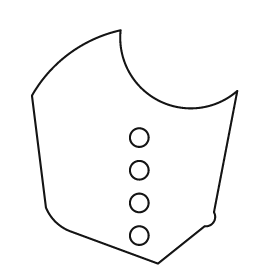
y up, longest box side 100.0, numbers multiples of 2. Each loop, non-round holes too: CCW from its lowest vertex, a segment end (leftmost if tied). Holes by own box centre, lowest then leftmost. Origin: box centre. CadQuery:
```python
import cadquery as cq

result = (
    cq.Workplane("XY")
    .moveTo(10.0, -50.0)
    .lineTo(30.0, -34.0)
    .threePointArc((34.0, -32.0), (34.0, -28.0))
    .lineTo(44.0, 24.0)
    .threePointArc((10.0, 20.0), (-6.0, 50.0))
    .threePointArc((-28.0, 40.0), (-44.0, 22.0))
    .lineTo(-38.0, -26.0)
    .threePointArc((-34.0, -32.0), (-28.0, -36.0))
    .close()
    .moveTo(2.0, -38.0)
    .circle(4.0)
    .moveTo(2.0, -24.0)
    .circle(4.0)
    .moveTo(2.0, -10.0)
    .circle(4.0)
    .moveTo(2.0, 4.0)
    .circle(4.0)
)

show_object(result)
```